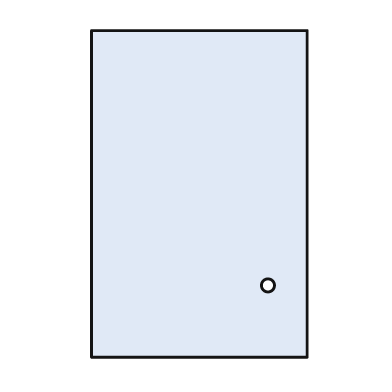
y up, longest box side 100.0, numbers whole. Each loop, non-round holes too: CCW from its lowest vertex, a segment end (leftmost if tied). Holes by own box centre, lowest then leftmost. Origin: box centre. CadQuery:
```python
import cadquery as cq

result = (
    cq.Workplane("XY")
    .moveTo(-33.0, -50.0)
    .lineTo(33.0, -50.0)
    .lineTo(33.0, 50.0)
    .lineTo(-33.0, 50.0)
    .close()
    .moveTo(21.0, -28.0)
    .circle(2.0)
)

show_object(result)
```